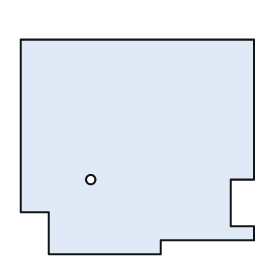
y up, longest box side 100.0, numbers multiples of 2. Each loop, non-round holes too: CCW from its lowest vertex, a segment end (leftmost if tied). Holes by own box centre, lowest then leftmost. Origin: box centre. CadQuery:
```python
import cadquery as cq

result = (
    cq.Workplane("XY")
    .moveTo(-38.0, -46.0)
    .lineTo(10.0, -46.0)
    .lineTo(10.0, -40.0)
    .lineTo(50.0, -40.0)
    .lineTo(50.0, -34.0)
    .lineTo(40.0, -34.0)
    .lineTo(40.0, -14.0)
    .lineTo(50.0, -14.0)
    .lineTo(50.0, 46.0)
    .lineTo(-50.0, 46.0)
    .lineTo(-50.0, -28.0)
    .lineTo(-38.0, -28.0)
    .close()
    .moveTo(-20.0, -14.0)
    .circle(2.0)
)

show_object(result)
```